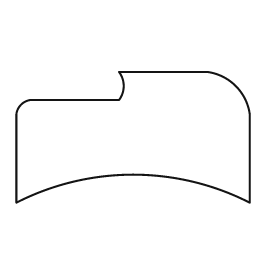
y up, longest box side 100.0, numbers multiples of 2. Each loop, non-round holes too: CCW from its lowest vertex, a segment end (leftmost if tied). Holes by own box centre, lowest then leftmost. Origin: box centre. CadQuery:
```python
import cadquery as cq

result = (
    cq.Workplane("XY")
    .moveTo(-50.0, -28.0)
    .threePointArc((0.0, -16.0), (50.0, -28.0))
    .lineTo(50.0, 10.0)
    .threePointArc((44.0, 22.0), (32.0, 28.0))
    .lineTo(-6.0, 28.0)
    .threePointArc((-4.0, 22.0), (-6.0, 16.0))
    .lineTo(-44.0, 16.0)
    .threePointArc((-48.0, 14.0), (-50.0, 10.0))
    .close()
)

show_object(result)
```